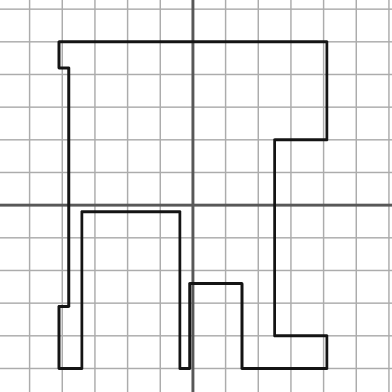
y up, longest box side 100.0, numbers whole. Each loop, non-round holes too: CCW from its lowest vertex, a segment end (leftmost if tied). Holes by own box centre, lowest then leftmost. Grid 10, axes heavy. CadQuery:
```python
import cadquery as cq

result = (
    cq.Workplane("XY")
    .moveTo(-41.0, -50.0)
    .lineTo(-34.0, -50.0)
    .lineTo(-34.0, -2.0)
    .lineTo(-4.0, -2.0)
    .lineTo(-4.0, -50.0)
    .lineTo(-1.0, -50.0)
    .lineTo(-1.0, -24.0)
    .lineTo(15.0, -24.0)
    .lineTo(15.0, -50.0)
    .lineTo(41.0, -50.0)
    .lineTo(41.0, -40.0)
    .lineTo(25.0, -40.0)
    .lineTo(25.0, 20.0)
    .lineTo(41.0, 20.0)
    .lineTo(41.0, 50.0)
    .lineTo(-41.0, 50.0)
    .lineTo(-41.0, 42.0)
    .lineTo(-38.0, 42.0)
    .lineTo(-38.0, -31.0)
    .lineTo(-41.0, -31.0)
    .close()
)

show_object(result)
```